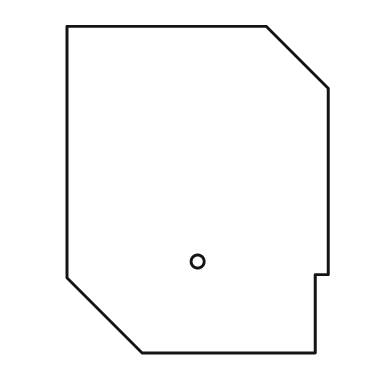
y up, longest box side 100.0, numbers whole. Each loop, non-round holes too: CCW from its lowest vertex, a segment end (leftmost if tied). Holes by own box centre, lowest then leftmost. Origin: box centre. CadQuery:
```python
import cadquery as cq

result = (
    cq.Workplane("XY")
    .moveTo(-17.0, -50.0)
    .lineTo(36.0, -50.0)
    .lineTo(36.0, -26.0)
    .lineTo(40.0, -26.0)
    .lineTo(40.0, 31.0)
    .lineTo(21.0, 50.0)
    .lineTo(-40.0, 50.0)
    .lineTo(-40.0, -27.0)
    .close()
    .moveTo(0.0, -22.0)
    .circle(2.0)
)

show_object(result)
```